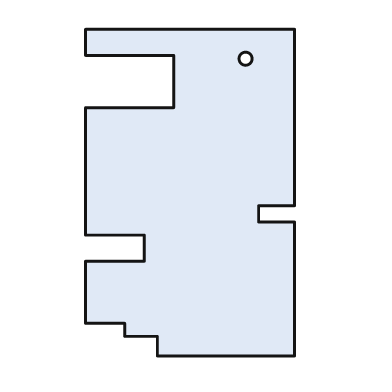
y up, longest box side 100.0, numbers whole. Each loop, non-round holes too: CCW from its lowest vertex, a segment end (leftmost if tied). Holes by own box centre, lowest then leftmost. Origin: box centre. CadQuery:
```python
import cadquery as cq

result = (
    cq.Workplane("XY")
    .moveTo(-10.0, -50.0)
    .lineTo(32.0, -50.0)
    .lineTo(32.0, -9.0)
    .lineTo(21.0, -9.0)
    .lineTo(21.0, -4.0)
    .lineTo(32.0, -4.0)
    .lineTo(32.0, 50.0)
    .lineTo(-32.0, 50.0)
    .lineTo(-32.0, 42.0)
    .lineTo(-5.0, 42.0)
    .lineTo(-5.0, 26.0)
    .lineTo(-32.0, 26.0)
    .lineTo(-32.0, -13.0)
    .lineTo(-14.0, -13.0)
    .lineTo(-14.0, -21.0)
    .lineTo(-32.0, -21.0)
    .lineTo(-32.0, -40.0)
    .lineTo(-20.0, -40.0)
    .lineTo(-20.0, -44.0)
    .lineTo(-10.0, -44.0)
    .close()
    .moveTo(17.0, 41.0)
    .circle(2.0)
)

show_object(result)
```